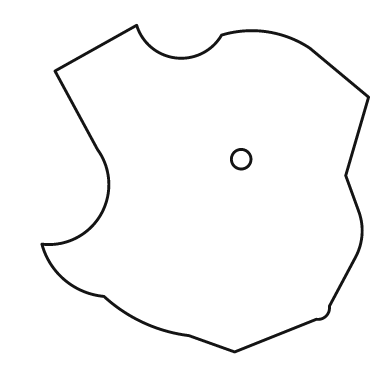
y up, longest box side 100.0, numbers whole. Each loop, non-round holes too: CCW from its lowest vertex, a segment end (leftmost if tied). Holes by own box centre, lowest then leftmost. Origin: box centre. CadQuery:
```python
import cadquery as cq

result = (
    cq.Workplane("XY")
    .moveTo(9.0, -50.0)
    .lineTo(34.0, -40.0)
    .threePointArc((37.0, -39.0), (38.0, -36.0))
    .lineTo(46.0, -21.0)
    .threePointArc((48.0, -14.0), (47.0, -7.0))
    .lineTo(43.0, 4.0)
    .lineTo(50.0, 28.0)
    .lineTo(32.0, 43.0)
    .threePointArc((19.0, 48.0), (5.0, 47.0))
    .threePointArc((-9.0, 40.0), (-21.0, 50.0))
    .lineTo(-46.0, 36.0)
    .lineTo(-33.0, 12.0)
    .threePointArc((-32.0, -8.0), (-50.0, -17.0))
    .threePointArc((-43.0, -28.0), (-31.0, -33.0))
    .threePointArc((-19.0, -41.0), (-5.0, -45.0))
    .close()
    .moveTo(11.0, 9.0)
    .circle(3.0)
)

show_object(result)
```